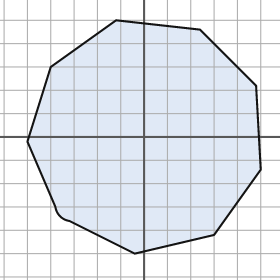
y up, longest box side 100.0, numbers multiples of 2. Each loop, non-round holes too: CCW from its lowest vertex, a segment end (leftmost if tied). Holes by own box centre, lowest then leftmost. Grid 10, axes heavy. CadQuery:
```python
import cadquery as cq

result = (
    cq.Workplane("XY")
    .moveTo(-4.0, -50.0)
    .lineTo(30.0, -42.0)
    .lineTo(50.0, -14.0)
    .lineTo(48.0, 22.0)
    .lineTo(24.0, 46.0)
    .lineTo(-12.0, 50.0)
    .lineTo(-40.0, 30.0)
    .lineTo(-50.0, -2.0)
    .lineTo(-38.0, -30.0)
    .threePointArc((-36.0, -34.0), (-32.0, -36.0))
    .close()
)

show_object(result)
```